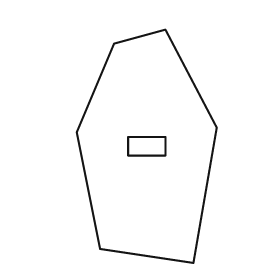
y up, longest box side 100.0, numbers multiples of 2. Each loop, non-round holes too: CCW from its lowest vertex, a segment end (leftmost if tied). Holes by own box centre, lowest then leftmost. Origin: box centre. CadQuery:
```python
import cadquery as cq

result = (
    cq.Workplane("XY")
    .moveTo(20.0, -50.0)
    .lineTo(30.0, 8.0)
    .lineTo(8.0, 50.0)
    .lineTo(-14.0, 44.0)
    .lineTo(-30.0, 6.0)
    .lineTo(-20.0, -44.0)
    .close()
    .moveTo(-8.0, -4.0)
    .lineTo(8.0, -4.0)
    .lineTo(8.0, 4.0)
    .lineTo(-8.0, 4.0)
    .close()
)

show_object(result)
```